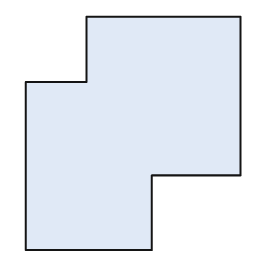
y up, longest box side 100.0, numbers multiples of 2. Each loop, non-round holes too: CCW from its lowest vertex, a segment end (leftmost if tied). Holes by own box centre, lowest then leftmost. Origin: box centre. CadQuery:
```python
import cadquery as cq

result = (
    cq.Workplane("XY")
    .moveTo(-46.0, -50.0)
    .lineTo(8.0, -50.0)
    .lineTo(8.0, -18.0)
    .lineTo(46.0, -18.0)
    .lineTo(46.0, 50.0)
    .lineTo(-20.0, 50.0)
    .lineTo(-20.0, 22.0)
    .lineTo(-46.0, 22.0)
    .close()
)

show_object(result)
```